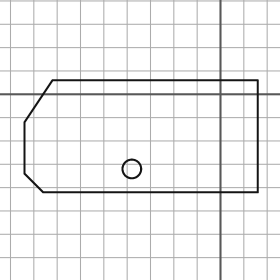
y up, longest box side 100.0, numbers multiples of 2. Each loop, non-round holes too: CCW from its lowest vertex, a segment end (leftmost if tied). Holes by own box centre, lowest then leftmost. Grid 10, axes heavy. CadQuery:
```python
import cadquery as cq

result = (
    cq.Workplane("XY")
    .moveTo(-76.0, -42.0)
    .lineTo(16.0, -42.0)
    .lineTo(16.0, 6.0)
    .lineTo(-72.0, 6.0)
    .lineTo(-84.0, -12.0)
    .lineTo(-84.0, -34.0)
    .close()
    .moveTo(-38.0, -32.0)
    .circle(4.0)
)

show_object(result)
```